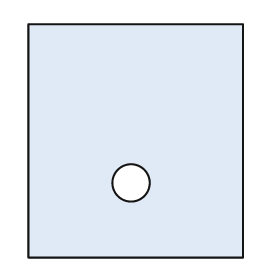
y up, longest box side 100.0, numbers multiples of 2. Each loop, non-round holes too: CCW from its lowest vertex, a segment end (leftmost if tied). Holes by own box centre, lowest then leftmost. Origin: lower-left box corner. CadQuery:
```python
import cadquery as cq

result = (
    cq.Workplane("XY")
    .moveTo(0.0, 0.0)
    .lineTo(92.0, 0.0)
    .lineTo(92.0, 100.0)
    .lineTo(0.0, 100.0)
    .close()
    .moveTo(44.0, 32.0)
    .circle(8.0)
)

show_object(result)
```